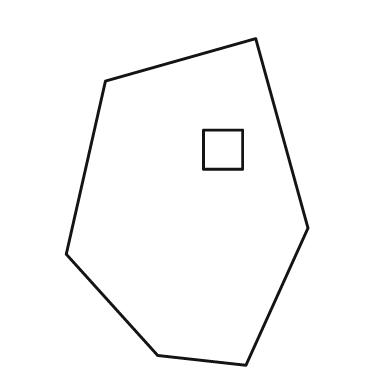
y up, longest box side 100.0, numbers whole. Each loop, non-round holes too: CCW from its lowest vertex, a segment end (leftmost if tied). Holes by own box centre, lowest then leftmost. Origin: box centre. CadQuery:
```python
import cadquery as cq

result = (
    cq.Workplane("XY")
    .moveTo(18.0, -50.0)
    .lineTo(37.0, -8.0)
    .lineTo(21.0, 50.0)
    .lineTo(-25.0, 37.0)
    .lineTo(-37.0, -16.0)
    .lineTo(-9.0, -47.0)
    .close()
    .moveTo(5.0, 10.0)
    .lineTo(17.0, 10.0)
    .lineTo(17.0, 22.0)
    .lineTo(5.0, 22.0)
    .close()
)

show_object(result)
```